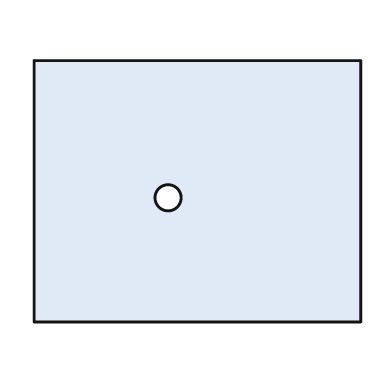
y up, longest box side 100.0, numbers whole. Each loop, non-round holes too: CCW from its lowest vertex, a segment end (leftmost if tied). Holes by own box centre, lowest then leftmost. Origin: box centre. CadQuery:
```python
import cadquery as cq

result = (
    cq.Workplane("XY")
    .moveTo(-50.0, -40.0)
    .lineTo(50.0, -40.0)
    .lineTo(50.0, 40.0)
    .lineTo(-50.0, 40.0)
    .close()
    .moveTo(-9.0, -2.0)
    .circle(4.0)
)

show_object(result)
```